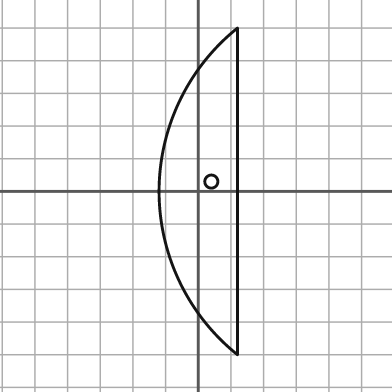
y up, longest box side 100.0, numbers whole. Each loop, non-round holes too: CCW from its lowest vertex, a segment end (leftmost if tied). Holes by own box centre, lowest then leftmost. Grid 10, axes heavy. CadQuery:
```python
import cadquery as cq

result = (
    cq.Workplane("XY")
    .moveTo(12.0, -50.0)
    .lineTo(12.0, 50.0)
    .threePointArc((-12.0, 0.0), (12.0, -50.0))
    .close()
    .moveTo(4.0, 3.0)
    .circle(2.0)
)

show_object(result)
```